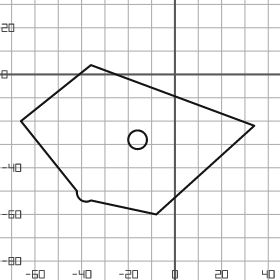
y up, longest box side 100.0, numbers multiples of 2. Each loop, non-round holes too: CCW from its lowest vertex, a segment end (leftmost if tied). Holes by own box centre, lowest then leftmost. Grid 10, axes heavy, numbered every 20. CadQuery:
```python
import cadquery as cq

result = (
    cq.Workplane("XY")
    .moveTo(-8.0, -60.0)
    .lineTo(34.0, -22.0)
    .lineTo(-36.0, 4.0)
    .lineTo(-66.0, -20.0)
    .lineTo(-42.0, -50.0)
    .threePointArc((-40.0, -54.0), (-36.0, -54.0))
    .close()
    .moveTo(-16.0, -28.0)
    .circle(4.0)
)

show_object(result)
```